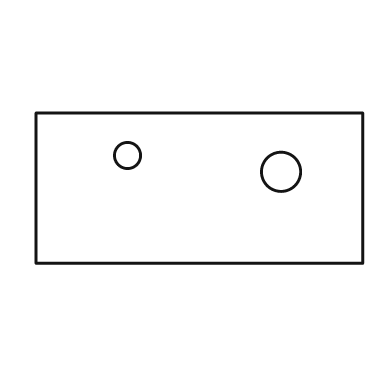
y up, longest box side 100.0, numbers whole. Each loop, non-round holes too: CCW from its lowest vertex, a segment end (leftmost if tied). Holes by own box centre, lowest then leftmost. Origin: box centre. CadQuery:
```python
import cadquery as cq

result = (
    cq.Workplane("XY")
    .moveTo(-50.0, -23.0)
    .lineTo(50.0, -23.0)
    .lineTo(50.0, 23.0)
    .lineTo(-50.0, 23.0)
    .close()
    .moveTo(25.0, 5.0)
    .circle(6.0)
    .moveTo(-22.0, 10.0)
    .circle(4.0)
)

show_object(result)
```